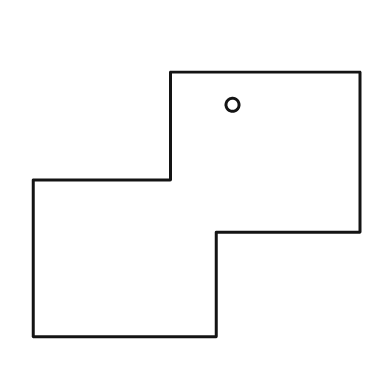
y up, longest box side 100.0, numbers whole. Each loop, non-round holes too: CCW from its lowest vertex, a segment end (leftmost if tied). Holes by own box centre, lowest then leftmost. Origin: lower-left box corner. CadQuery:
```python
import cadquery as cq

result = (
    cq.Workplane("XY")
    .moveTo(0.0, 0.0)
    .lineTo(56.0, 0.0)
    .lineTo(56.0, 32.0)
    .lineTo(100.0, 32.0)
    .lineTo(100.0, 81.0)
    .lineTo(42.0, 81.0)
    .lineTo(42.0, 48.0)
    .lineTo(0.0, 48.0)
    .close()
    .moveTo(61.0, 71.0)
    .circle(2.0)
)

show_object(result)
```